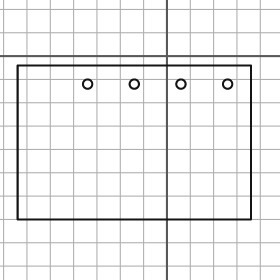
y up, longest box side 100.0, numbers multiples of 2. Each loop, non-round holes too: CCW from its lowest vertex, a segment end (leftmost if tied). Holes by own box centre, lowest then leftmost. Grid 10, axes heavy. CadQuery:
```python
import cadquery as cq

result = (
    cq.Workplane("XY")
    .moveTo(-64.0, -70.0)
    .lineTo(36.0, -70.0)
    .lineTo(36.0, -4.0)
    .lineTo(-64.0, -4.0)
    .close()
    .moveTo(-34.0, -12.0)
    .circle(2.0)
    .moveTo(-14.0, -12.0)
    .circle(2.0)
    .moveTo(6.0, -12.0)
    .circle(2.0)
    .moveTo(26.0, -12.0)
    .circle(2.0)
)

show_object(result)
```